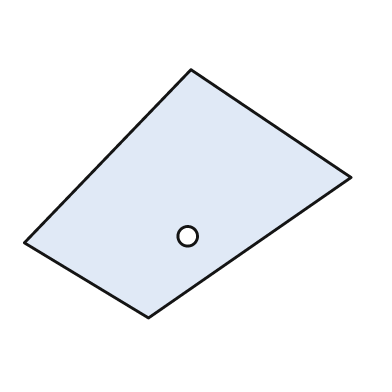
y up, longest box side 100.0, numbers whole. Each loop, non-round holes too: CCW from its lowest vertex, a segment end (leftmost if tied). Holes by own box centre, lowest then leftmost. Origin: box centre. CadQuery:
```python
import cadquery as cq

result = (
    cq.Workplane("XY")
    .moveTo(-12.0, -38.0)
    .lineTo(50.0, 5.0)
    .lineTo(1.0, 38.0)
    .lineTo(-50.0, -15.0)
    .close()
    .moveTo(0.0, -13.0)
    .circle(3.0)
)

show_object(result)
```